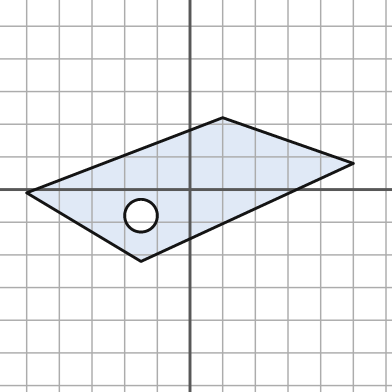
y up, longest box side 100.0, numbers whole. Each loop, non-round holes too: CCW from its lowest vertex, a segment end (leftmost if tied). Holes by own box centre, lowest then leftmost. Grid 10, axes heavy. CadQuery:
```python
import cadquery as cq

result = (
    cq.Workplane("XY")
    .moveTo(-15.0, -22.0)
    .lineTo(50.0, 8.0)
    .lineTo(10.0, 22.0)
    .lineTo(-50.0, -1.0)
    .close()
    .moveTo(-15.0, -8.0)
    .circle(5.0)
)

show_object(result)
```